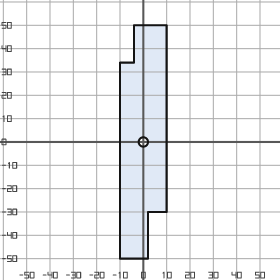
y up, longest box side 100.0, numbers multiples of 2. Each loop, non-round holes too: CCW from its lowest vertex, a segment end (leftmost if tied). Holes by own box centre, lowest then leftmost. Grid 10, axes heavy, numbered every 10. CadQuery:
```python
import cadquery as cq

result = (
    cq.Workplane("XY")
    .moveTo(-10.0, -50.0)
    .lineTo(2.0, -50.0)
    .lineTo(2.0, -30.0)
    .lineTo(10.0, -30.0)
    .lineTo(10.0, 50.0)
    .lineTo(-4.0, 50.0)
    .lineTo(-4.0, 34.0)
    .lineTo(-10.0, 34.0)
    .close()
    .moveTo(0.0, 0.0)
    .circle(2.0)
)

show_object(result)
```